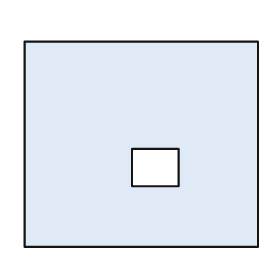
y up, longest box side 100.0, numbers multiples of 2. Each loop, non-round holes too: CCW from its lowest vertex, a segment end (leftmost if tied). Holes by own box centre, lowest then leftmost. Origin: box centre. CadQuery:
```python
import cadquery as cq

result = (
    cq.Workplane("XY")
    .moveTo(-50.0, -44.0)
    .lineTo(50.0, -44.0)
    .lineTo(50.0, 44.0)
    .lineTo(-50.0, 44.0)
    .close()
    .moveTo(-4.0, -18.0)
    .lineTo(16.0, -18.0)
    .lineTo(16.0, -2.0)
    .lineTo(-4.0, -2.0)
    .close()
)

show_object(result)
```